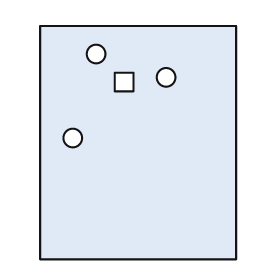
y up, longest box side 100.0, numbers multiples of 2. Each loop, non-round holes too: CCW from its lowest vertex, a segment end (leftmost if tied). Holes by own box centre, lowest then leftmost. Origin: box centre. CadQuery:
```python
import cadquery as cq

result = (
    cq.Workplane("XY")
    .moveTo(-42.0, -50.0)
    .lineTo(42.0, -50.0)
    .lineTo(42.0, 50.0)
    .lineTo(-42.0, 50.0)
    .close()
    .moveTo(-28.0, 2.0)
    .circle(4.0)
    .moveTo(-10.0, 22.0)
    .lineTo(-2.0, 22.0)
    .lineTo(-2.0, 30.0)
    .lineTo(-10.0, 30.0)
    .close()
    .moveTo(12.0, 28.0)
    .circle(4.0)
    .moveTo(-18.0, 38.0)
    .circle(4.0)
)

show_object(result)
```